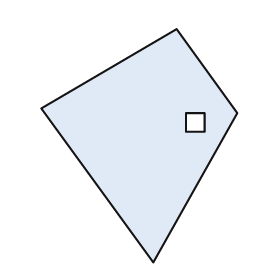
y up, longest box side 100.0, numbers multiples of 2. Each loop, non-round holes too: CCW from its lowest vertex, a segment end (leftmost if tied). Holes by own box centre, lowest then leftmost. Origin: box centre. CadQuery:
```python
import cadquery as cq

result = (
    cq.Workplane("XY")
    .moveTo(6.0, -50.0)
    .lineTo(42.0, 14.0)
    .lineTo(16.0, 50.0)
    .lineTo(-42.0, 16.0)
    .close()
    .moveTo(20.0, 6.0)
    .lineTo(28.0, 6.0)
    .lineTo(28.0, 14.0)
    .lineTo(20.0, 14.0)
    .close()
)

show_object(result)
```